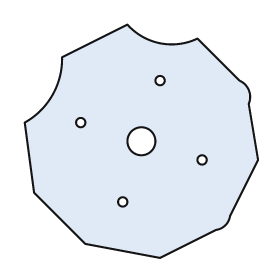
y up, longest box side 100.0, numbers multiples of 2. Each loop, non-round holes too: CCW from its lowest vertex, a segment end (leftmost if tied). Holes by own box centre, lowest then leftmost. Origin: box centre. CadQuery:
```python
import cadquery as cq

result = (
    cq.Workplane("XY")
    .moveTo(8.0, -50.0)
    .lineTo(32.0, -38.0)
    .threePointArc((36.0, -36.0), (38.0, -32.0))
    .lineTo(50.0, -8.0)
    .lineTo(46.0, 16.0)
    .threePointArc((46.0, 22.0), (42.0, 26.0))
    .lineTo(24.0, 44.0)
    .threePointArc((8.0, 42.0), (-6.0, 50.0))
    .lineTo(-34.0, 36.0)
    .threePointArc((-38.0, 20.0), (-50.0, 8.0))
    .lineTo(-46.0, -22.0)
    .lineTo(-24.0, -44.0)
    .close()
    .moveTo(-8.0, -26.0)
    .circle(2.0)
    .moveTo(26.0, -8.0)
    .circle(2.0)
    .moveTo(0.0, 0.0)
    .circle(6.0)
    .moveTo(-26.0, 8.0)
    .circle(2.0)
    .moveTo(8.0, 26.0)
    .circle(2.0)
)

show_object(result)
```